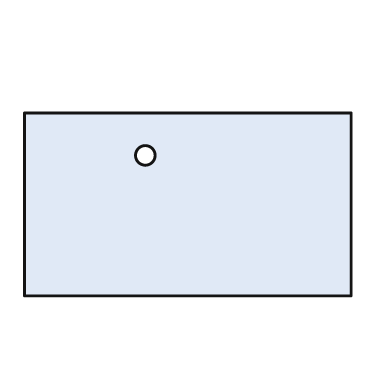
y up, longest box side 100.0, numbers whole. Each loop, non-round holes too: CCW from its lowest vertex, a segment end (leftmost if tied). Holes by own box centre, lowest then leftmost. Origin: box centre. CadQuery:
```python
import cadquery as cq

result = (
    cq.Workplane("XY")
    .moveTo(-50.0, -28.0)
    .lineTo(50.0, -28.0)
    .lineTo(50.0, 28.0)
    .lineTo(-50.0, 28.0)
    .close()
    .moveTo(-13.0, 15.0)
    .circle(3.0)
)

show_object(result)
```